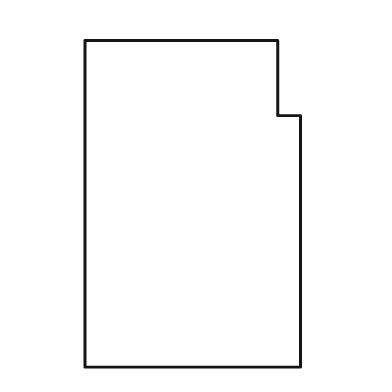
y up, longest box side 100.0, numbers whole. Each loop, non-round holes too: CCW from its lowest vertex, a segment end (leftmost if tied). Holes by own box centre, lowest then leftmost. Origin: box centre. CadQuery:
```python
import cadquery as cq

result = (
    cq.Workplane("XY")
    .moveTo(-33.0, -50.0)
    .lineTo(33.0, -50.0)
    .lineTo(33.0, 27.0)
    .lineTo(26.0, 27.0)
    .lineTo(26.0, 50.0)
    .lineTo(-33.0, 50.0)
    .close()
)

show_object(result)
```